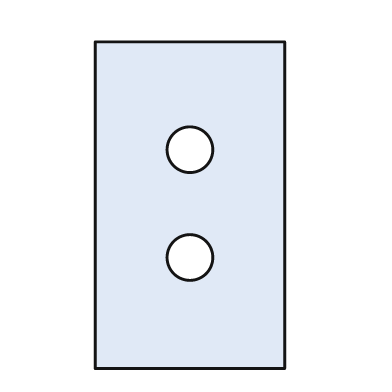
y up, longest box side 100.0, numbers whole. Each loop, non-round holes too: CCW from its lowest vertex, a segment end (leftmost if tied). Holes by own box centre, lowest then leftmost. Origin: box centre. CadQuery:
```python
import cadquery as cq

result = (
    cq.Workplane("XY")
    .moveTo(-29.0, -50.0)
    .lineTo(29.0, -50.0)
    .lineTo(29.0, 50.0)
    .lineTo(-29.0, 50.0)
    .close()
    .moveTo(0.0, -16.0)
    .circle(7.0)
    .moveTo(0.0, 17.0)
    .circle(7.0)
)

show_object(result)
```